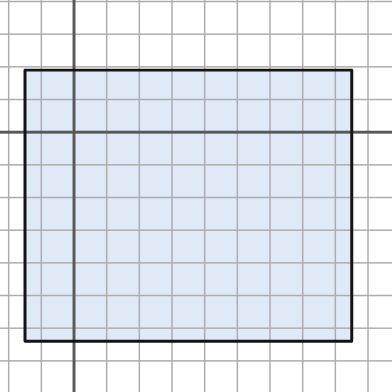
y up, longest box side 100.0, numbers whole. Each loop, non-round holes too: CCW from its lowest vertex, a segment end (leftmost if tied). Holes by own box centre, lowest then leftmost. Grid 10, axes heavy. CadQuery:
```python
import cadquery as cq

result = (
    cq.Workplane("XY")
    .moveTo(-15.0, -64.0)
    .lineTo(85.0, -64.0)
    .lineTo(85.0, 19.0)
    .lineTo(-15.0, 19.0)
    .close()
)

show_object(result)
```